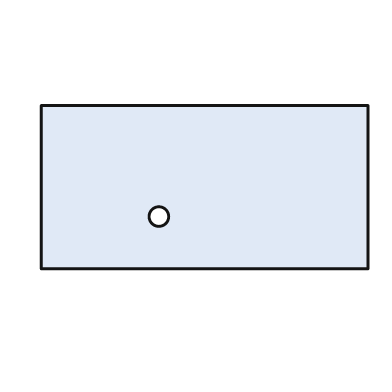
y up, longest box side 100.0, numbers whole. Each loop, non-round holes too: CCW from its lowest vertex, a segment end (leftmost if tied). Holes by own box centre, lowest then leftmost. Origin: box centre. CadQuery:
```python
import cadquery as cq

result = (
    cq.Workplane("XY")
    .moveTo(-50.0, -25.0)
    .lineTo(50.0, -25.0)
    .lineTo(50.0, 25.0)
    .lineTo(-50.0, 25.0)
    .close()
    .moveTo(-14.0, -9.0)
    .circle(3.0)
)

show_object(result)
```